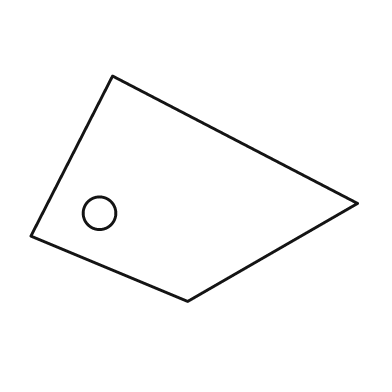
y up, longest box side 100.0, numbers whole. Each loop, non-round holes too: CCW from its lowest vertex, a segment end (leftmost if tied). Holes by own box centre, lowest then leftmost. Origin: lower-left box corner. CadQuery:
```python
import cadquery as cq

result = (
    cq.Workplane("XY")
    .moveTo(48.0, 0.0)
    .lineTo(100.0, 30.0)
    .lineTo(25.0, 69.0)
    .lineTo(0.0, 20.0)
    .close()
    .moveTo(21.0, 27.0)
    .circle(5.0)
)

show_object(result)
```